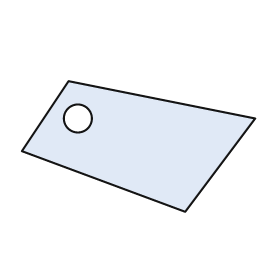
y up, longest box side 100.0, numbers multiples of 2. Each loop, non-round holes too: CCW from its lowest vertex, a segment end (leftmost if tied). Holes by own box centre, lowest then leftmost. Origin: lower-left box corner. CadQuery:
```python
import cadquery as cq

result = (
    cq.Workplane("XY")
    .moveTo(70.0, 0.0)
    .lineTo(100.0, 40.0)
    .lineTo(20.0, 56.0)
    .lineTo(0.0, 26.0)
    .close()
    .moveTo(24.0, 40.0)
    .circle(6.0)
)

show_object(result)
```